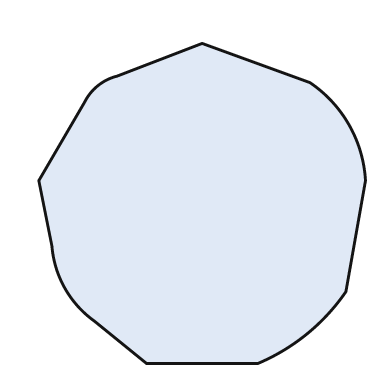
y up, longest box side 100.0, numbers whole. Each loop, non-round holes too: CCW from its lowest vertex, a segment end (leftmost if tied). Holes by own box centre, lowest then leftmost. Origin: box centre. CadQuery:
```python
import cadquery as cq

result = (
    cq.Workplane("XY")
    .moveTo(-17.0, -49.0)
    .lineTo(17.0, -49.0)
    .threePointArc((32.0, -40.0), (44.0, -27.0))
    .lineTo(50.0, 7.0)
    .threePointArc((45.0, 24.0), (33.0, 37.0))
    .lineTo(0.0, 49.0)
    .lineTo(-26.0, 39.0)
    .threePointArc((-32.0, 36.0), (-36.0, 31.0))
    .lineTo(-50.0, 7.0)
    .lineTo(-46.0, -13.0)
    .threePointArc((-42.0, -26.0), (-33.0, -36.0))
    .close()
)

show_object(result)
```